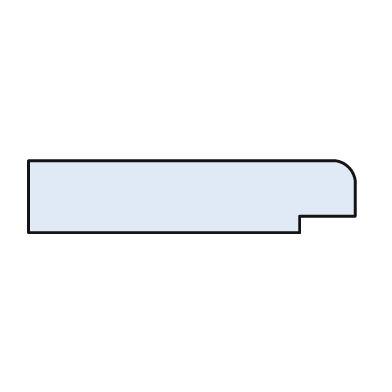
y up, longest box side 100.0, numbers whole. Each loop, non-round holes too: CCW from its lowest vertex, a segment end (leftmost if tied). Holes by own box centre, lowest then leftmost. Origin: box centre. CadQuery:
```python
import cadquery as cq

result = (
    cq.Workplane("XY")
    .moveTo(-50.0, -11.0)
    .lineTo(33.0, -11.0)
    .lineTo(33.0, -6.0)
    .lineTo(50.0, -6.0)
    .lineTo(50.0, 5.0)
    .threePointArc((48.0, 9.0), (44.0, 11.0))
    .lineTo(-50.0, 11.0)
    .close()
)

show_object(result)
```